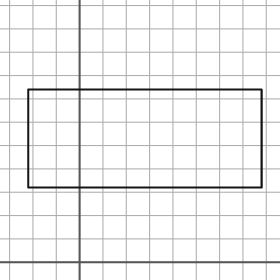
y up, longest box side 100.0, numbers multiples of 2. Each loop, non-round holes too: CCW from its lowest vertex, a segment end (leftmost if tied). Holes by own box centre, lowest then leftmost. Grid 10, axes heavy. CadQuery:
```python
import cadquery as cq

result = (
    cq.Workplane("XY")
    .moveTo(-22.0, 32.0)
    .lineTo(78.0, 32.0)
    .lineTo(78.0, 74.0)
    .lineTo(-22.0, 74.0)
    .close()
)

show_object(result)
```